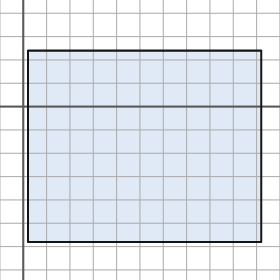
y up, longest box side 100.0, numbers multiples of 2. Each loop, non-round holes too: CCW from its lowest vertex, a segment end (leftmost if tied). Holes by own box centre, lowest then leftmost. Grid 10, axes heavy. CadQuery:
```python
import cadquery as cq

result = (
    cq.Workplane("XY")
    .moveTo(2.0, -58.0)
    .lineTo(102.0, -58.0)
    .lineTo(102.0, 24.0)
    .lineTo(2.0, 24.0)
    .close()
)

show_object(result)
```